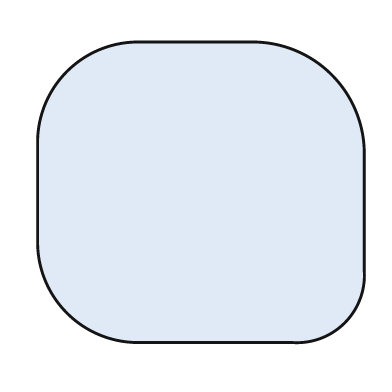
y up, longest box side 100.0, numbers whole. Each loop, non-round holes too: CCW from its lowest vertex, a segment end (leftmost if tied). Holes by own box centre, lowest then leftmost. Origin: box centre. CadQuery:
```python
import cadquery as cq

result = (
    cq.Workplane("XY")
    .moveTo(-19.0, -46.0)
    .lineTo(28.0, -46.0)
    .threePointArc((44.0, -40.0), (50.0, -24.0))
    .lineTo(50.0, 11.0)
    .threePointArc((40.0, 36.0), (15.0, 46.0))
    .lineTo(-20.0, 46.0)
    .threePointArc((-41.0, 37.0), (-50.0, 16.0))
    .lineTo(-50.0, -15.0)
    .threePointArc((-41.0, -37.0), (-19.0, -46.0))
    .close()
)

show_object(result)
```